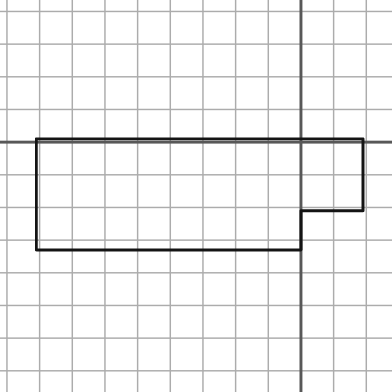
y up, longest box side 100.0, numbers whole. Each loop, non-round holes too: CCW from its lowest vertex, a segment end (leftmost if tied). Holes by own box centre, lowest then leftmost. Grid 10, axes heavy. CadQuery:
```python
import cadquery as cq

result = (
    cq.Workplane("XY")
    .moveTo(-81.0, -33.0)
    .lineTo(0.0, -33.0)
    .lineTo(0.0, -21.0)
    .lineTo(19.0, -21.0)
    .lineTo(19.0, 1.0)
    .lineTo(-81.0, 1.0)
    .close()
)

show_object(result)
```